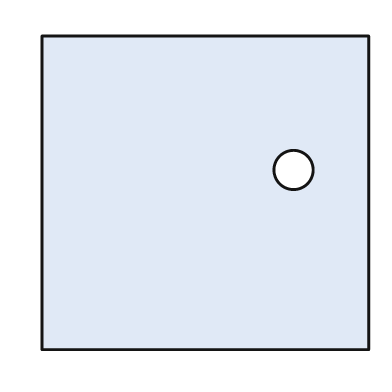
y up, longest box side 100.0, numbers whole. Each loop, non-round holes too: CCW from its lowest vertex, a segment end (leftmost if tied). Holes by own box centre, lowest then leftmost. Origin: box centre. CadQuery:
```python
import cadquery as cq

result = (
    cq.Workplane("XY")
    .moveTo(-50.0, -48.0)
    .lineTo(50.0, -48.0)
    .lineTo(50.0, 48.0)
    .lineTo(-50.0, 48.0)
    .close()
    .moveTo(27.0, 7.0)
    .circle(6.0)
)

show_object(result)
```